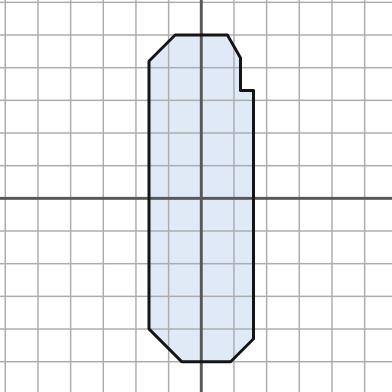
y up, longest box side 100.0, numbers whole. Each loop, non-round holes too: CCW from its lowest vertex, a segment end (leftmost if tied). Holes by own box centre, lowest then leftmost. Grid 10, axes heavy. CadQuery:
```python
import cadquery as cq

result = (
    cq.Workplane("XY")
    .moveTo(-6.0, -50.0)
    .lineTo(9.0, -50.0)
    .lineTo(16.0, -43.0)
    .lineTo(16.0, 33.0)
    .lineTo(12.0, 33.0)
    .lineTo(12.0, 43.0)
    .lineTo(8.0, 50.0)
    .lineTo(-8.0, 50.0)
    .lineTo(-16.0, 42.0)
    .lineTo(-16.0, -40.0)
    .close()
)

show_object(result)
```